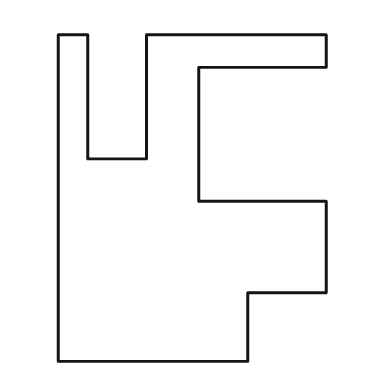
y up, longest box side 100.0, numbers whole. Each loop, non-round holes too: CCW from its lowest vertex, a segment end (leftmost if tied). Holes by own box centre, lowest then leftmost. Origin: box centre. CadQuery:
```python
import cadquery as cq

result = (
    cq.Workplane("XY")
    .moveTo(-41.0, -50.0)
    .lineTo(17.0, -50.0)
    .lineTo(17.0, -29.0)
    .lineTo(41.0, -29.0)
    .lineTo(41.0, -1.0)
    .lineTo(2.0, -1.0)
    .lineTo(2.0, 40.0)
    .lineTo(41.0, 40.0)
    .lineTo(41.0, 50.0)
    .lineTo(-14.0, 50.0)
    .lineTo(-14.0, 12.0)
    .lineTo(-32.0, 12.0)
    .lineTo(-32.0, 50.0)
    .lineTo(-41.0, 50.0)
    .close()
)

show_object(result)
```